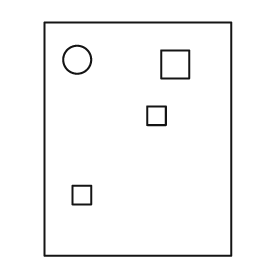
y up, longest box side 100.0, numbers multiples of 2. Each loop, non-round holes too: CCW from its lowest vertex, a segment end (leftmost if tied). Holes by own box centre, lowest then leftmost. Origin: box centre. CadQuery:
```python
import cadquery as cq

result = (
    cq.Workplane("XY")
    .moveTo(-40.0, -50.0)
    .lineTo(40.0, -50.0)
    .lineTo(40.0, 50.0)
    .lineTo(-40.0, 50.0)
    .close()
    .moveTo(-28.0, -28.0)
    .lineTo(-20.0, -28.0)
    .lineTo(-20.0, -20.0)
    .lineTo(-28.0, -20.0)
    .close()
    .moveTo(4.0, 6.0)
    .lineTo(12.0, 6.0)
    .lineTo(12.0, 14.0)
    .lineTo(4.0, 14.0)
    .close()
    .moveTo(10.0, 26.0)
    .lineTo(22.0, 26.0)
    .lineTo(22.0, 38.0)
    .lineTo(10.0, 38.0)
    .close()
    .moveTo(-26.0, 34.0)
    .circle(6.0)
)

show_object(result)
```